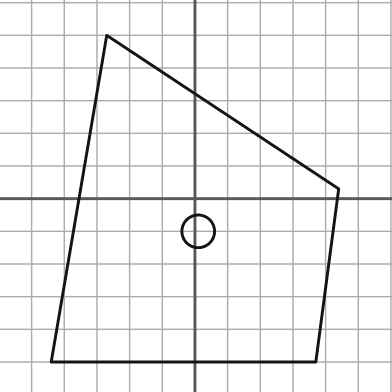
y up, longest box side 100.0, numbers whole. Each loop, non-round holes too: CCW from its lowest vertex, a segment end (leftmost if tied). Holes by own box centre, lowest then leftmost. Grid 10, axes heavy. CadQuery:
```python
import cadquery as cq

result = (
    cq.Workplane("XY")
    .moveTo(-44.0, -50.0)
    .lineTo(37.0, -50.0)
    .lineTo(44.0, 3.0)
    .lineTo(-27.0, 50.0)
    .close()
    .moveTo(1.0, -10.0)
    .circle(5.0)
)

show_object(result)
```